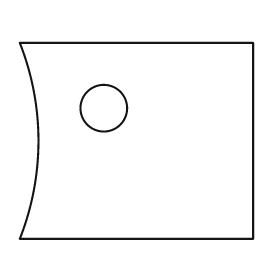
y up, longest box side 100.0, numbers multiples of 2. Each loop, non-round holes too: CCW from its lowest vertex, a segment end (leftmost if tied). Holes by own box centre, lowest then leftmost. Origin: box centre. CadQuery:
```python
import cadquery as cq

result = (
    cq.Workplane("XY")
    .moveTo(-50.0, -42.0)
    .lineTo(50.0, -42.0)
    .lineTo(50.0, 42.0)
    .lineTo(-50.0, 42.0)
    .threePointArc((-42.0, 0.0), (-50.0, -42.0))
    .close()
    .moveTo(-14.0, 14.0)
    .circle(10.0)
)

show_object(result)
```